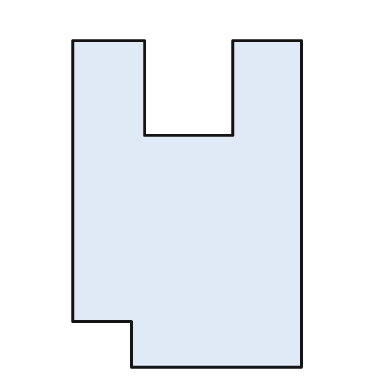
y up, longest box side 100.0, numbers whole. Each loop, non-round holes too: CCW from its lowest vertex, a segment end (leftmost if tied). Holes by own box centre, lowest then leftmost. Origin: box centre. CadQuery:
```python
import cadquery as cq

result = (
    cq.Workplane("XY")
    .moveTo(-17.0, -50.0)
    .lineTo(35.0, -50.0)
    .lineTo(35.0, 50.0)
    .lineTo(14.0, 50.0)
    .lineTo(14.0, 21.0)
    .lineTo(-13.0, 21.0)
    .lineTo(-13.0, 50.0)
    .lineTo(-35.0, 50.0)
    .lineTo(-35.0, -36.0)
    .lineTo(-17.0, -36.0)
    .close()
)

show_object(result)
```